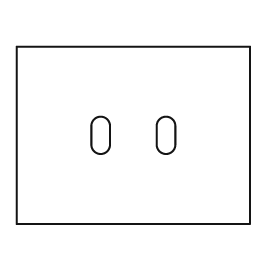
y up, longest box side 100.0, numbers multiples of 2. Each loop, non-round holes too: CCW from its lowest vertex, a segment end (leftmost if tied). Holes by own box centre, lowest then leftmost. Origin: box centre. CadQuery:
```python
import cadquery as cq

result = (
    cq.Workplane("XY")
    .moveTo(-50.0, -38.0)
    .lineTo(50.0, -38.0)
    .lineTo(50.0, 38.0)
    .lineTo(-50.0, 38.0)
    .close()
    .moveTo(-18.0, -4.0)
    .threePointArc((-14.0, -8.0), (-10.0, -4.0))
    .lineTo(-10.0, 4.0)
    .threePointArc((-14.0, 8.0), (-18.0, 4.0))
    .close()
    .moveTo(10.0, -4.0)
    .threePointArc((14.0, -8.0), (18.0, -4.0))
    .lineTo(18.0, 4.0)
    .threePointArc((14.0, 8.0), (10.0, 4.0))
    .close()
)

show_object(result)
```